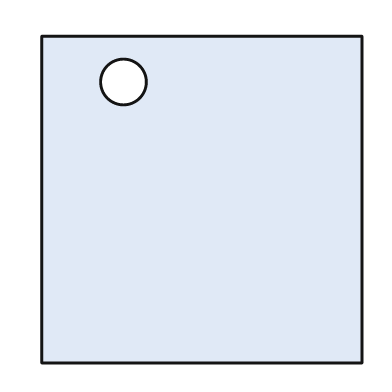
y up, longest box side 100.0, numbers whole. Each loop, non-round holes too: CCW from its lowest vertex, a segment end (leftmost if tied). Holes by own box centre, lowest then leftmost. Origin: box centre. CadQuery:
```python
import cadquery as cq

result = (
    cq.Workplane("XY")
    .moveTo(-49.0, -50.0)
    .lineTo(49.0, -50.0)
    .lineTo(49.0, 50.0)
    .lineTo(-49.0, 50.0)
    .close()
    .moveTo(-24.0, 36.0)
    .circle(7.0)
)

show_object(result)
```